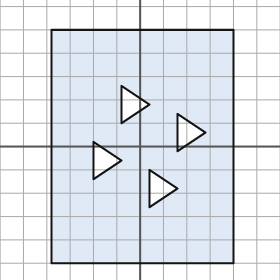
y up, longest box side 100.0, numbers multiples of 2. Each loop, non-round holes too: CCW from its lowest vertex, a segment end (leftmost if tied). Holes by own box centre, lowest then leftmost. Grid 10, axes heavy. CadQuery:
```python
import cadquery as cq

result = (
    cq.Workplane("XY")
    .moveTo(-38.0, -50.0)
    .lineTo(40.0, -50.0)
    .lineTo(40.0, 50.0)
    .lineTo(-38.0, 50.0)
    .close()
    .moveTo(4.0, -26.0)
    .lineTo(16.0, -18.0)
    .lineTo(4.0, -10.0)
    .close()
    .moveTo(-20.0, -14.0)
    .lineTo(-8.0, -6.0)
    .lineTo(-20.0, 2.0)
    .close()
    .moveTo(16.0, -2.0)
    .lineTo(28.0, 6.0)
    .lineTo(16.0, 14.0)
    .close()
    .moveTo(-8.0, 10.0)
    .lineTo(4.0, 18.0)
    .lineTo(-8.0, 26.0)
    .close()
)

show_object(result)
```